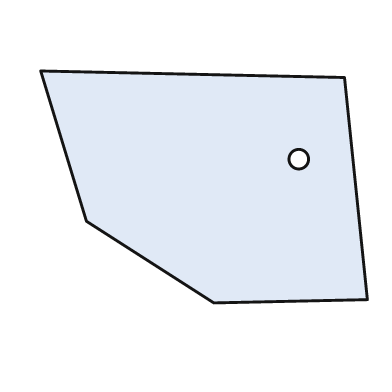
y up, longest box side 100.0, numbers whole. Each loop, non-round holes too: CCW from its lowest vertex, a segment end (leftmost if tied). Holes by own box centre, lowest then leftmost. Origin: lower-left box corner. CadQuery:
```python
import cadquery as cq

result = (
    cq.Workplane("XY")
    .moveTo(53.0, 0.0)
    .lineTo(100.0, 1.0)
    .lineTo(93.0, 69.0)
    .lineTo(0.0, 71.0)
    .lineTo(14.0, 25.0)
    .close()
    .moveTo(79.0, 44.0)
    .circle(3.0)
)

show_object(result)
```